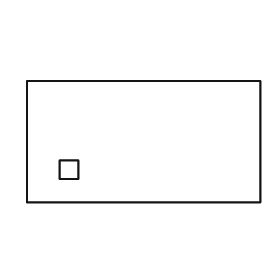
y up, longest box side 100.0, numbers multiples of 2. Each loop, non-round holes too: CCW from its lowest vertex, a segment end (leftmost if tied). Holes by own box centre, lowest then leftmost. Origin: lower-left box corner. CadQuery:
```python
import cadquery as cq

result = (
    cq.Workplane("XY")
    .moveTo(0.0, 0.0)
    .lineTo(100.0, 0.0)
    .lineTo(100.0, 52.0)
    .lineTo(0.0, 52.0)
    .close()
    .moveTo(14.0, 10.0)
    .lineTo(22.0, 10.0)
    .lineTo(22.0, 18.0)
    .lineTo(14.0, 18.0)
    .close()
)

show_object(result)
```